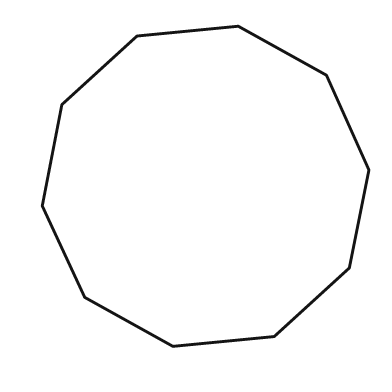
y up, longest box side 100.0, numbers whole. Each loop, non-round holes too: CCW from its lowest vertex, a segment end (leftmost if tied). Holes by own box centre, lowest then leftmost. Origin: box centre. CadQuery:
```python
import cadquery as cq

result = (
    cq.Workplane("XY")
    .moveTo(-10.0, -49.0)
    .lineTo(21.0, -46.0)
    .lineTo(44.0, -25.0)
    .lineTo(50.0, 5.0)
    .lineTo(37.0, 34.0)
    .lineTo(10.0, 49.0)
    .lineTo(-21.0, 46.0)
    .lineTo(-44.0, 25.0)
    .lineTo(-50.0, -6.0)
    .lineTo(-37.0, -34.0)
    .close()
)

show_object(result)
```